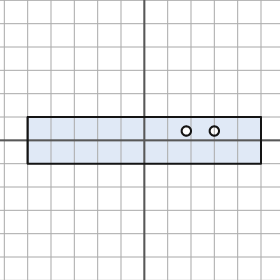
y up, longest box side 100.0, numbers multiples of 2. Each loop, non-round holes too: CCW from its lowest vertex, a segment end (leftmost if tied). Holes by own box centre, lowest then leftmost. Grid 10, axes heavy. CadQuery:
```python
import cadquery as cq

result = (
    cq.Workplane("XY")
    .moveTo(-50.0, -10.0)
    .lineTo(50.0, -10.0)
    .lineTo(50.0, 10.0)
    .lineTo(-50.0, 10.0)
    .close()
    .moveTo(18.0, 4.0)
    .circle(2.0)
    .moveTo(30.0, 4.0)
    .circle(2.0)
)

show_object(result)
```